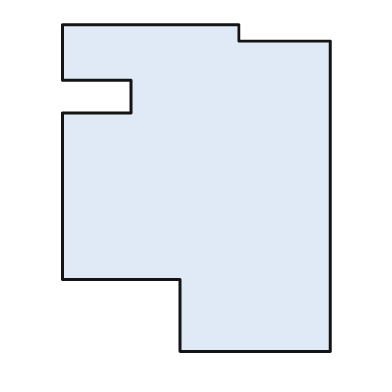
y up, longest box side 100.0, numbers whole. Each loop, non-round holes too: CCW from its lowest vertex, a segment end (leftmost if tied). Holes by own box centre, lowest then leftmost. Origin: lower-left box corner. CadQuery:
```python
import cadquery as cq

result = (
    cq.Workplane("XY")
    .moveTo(36.0, 0.0)
    .lineTo(82.0, 0.0)
    .lineTo(82.0, 95.0)
    .lineTo(54.0, 95.0)
    .lineTo(54.0, 100.0)
    .lineTo(0.0, 100.0)
    .lineTo(0.0, 83.0)
    .lineTo(21.0, 83.0)
    .lineTo(21.0, 73.0)
    .lineTo(0.0, 73.0)
    .lineTo(0.0, 22.0)
    .lineTo(36.0, 22.0)
    .close()
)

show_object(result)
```